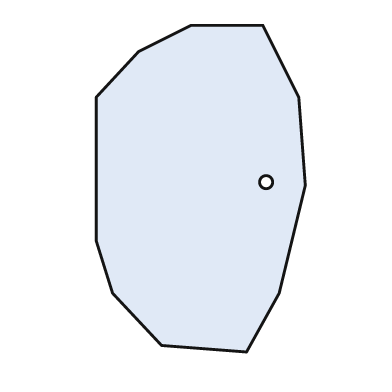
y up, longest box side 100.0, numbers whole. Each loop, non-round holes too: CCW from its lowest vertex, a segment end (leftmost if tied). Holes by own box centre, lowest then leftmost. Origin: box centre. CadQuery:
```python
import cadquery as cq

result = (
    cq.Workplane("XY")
    .moveTo(14.0, -50.0)
    .lineTo(24.0, -32.0)
    .lineTo(32.0, 1.0)
    .lineTo(30.0, 28.0)
    .lineTo(19.0, 50.0)
    .lineTo(-3.0, 50.0)
    .lineTo(-19.0, 42.0)
    .lineTo(-32.0, 28.0)
    .lineTo(-32.0, -16.0)
    .lineTo(-27.0, -32.0)
    .lineTo(-12.0, -48.0)
    .close()
    .moveTo(20.0, 2.0)
    .circle(2.0)
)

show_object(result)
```